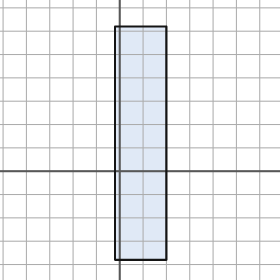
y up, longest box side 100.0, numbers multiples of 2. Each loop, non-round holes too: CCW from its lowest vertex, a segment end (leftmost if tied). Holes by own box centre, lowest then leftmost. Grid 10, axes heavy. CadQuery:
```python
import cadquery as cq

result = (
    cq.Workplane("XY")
    .moveTo(-2.0, -38.0)
    .lineTo(20.0, -38.0)
    .lineTo(20.0, 62.0)
    .lineTo(-2.0, 62.0)
    .close()
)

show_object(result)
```